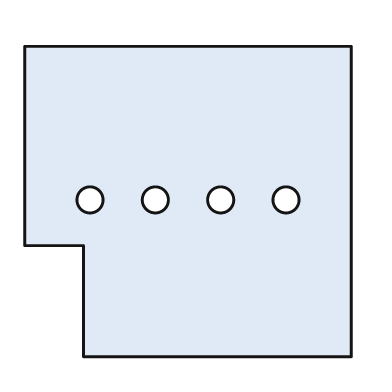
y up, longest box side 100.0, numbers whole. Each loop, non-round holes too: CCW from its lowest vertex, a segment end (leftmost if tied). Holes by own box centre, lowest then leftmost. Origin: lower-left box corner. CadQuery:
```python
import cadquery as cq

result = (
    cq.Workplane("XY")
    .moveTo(18.0, 0.0)
    .lineTo(100.0, 0.0)
    .lineTo(100.0, 95.0)
    .lineTo(0.0, 95.0)
    .lineTo(0.0, 34.0)
    .lineTo(18.0, 34.0)
    .close()
    .moveTo(20.0, 48.0)
    .circle(4.0)
    .moveTo(40.0, 48.0)
    .circle(4.0)
    .moveTo(60.0, 48.0)
    .circle(4.0)
    .moveTo(80.0, 48.0)
    .circle(4.0)
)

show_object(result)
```